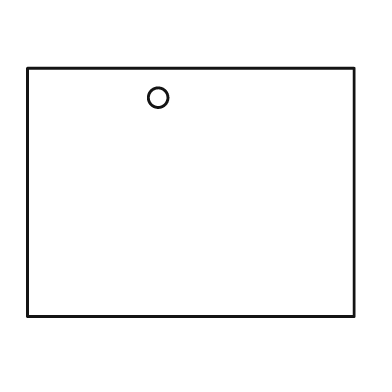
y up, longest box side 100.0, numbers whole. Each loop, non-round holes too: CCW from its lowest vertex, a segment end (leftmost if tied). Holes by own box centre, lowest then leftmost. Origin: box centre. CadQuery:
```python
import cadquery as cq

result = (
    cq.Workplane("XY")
    .moveTo(-50.0, -38.0)
    .lineTo(50.0, -38.0)
    .lineTo(50.0, 38.0)
    .lineTo(-50.0, 38.0)
    .close()
    .moveTo(-10.0, 29.0)
    .circle(3.0)
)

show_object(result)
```